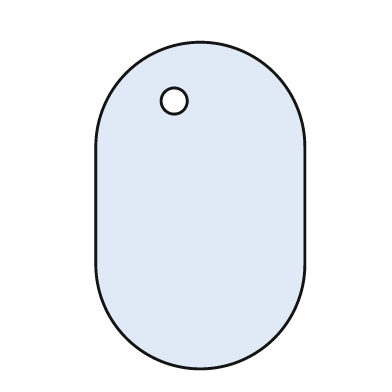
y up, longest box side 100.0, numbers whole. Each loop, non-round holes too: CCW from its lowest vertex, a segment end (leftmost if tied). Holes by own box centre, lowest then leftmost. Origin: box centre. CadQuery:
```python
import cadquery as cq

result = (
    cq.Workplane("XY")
    .moveTo(-32.0, -18.0)
    .threePointArc((0.0, -50.0), (32.0, -18.0))
    .lineTo(32.0, 18.0)
    .threePointArc((0.0, 50.0), (-32.0, 18.0))
    .close()
    .moveTo(-8.0, 32.0)
    .circle(4.0)
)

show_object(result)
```